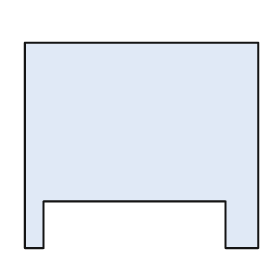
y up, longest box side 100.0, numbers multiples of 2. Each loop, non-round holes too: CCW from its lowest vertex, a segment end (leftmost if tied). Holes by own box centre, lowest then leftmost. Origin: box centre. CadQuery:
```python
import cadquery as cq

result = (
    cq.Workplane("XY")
    .moveTo(-50.0, -44.0)
    .lineTo(-42.0, -44.0)
    .lineTo(-42.0, -24.0)
    .lineTo(36.0, -24.0)
    .lineTo(36.0, -44.0)
    .lineTo(50.0, -44.0)
    .lineTo(50.0, 44.0)
    .lineTo(-50.0, 44.0)
    .close()
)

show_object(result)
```